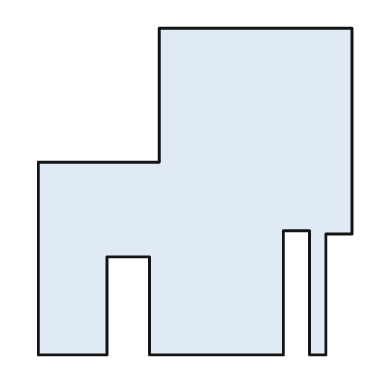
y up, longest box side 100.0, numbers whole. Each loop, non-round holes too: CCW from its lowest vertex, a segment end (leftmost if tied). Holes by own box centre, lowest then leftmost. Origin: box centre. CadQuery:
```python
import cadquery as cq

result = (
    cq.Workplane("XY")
    .moveTo(-48.0, -50.0)
    .lineTo(-27.0, -50.0)
    .lineTo(-27.0, -20.0)
    .lineTo(-14.0, -20.0)
    .lineTo(-14.0, -50.0)
    .lineTo(27.0, -50.0)
    .lineTo(27.0, -12.0)
    .lineTo(35.0, -12.0)
    .lineTo(35.0, -50.0)
    .lineTo(40.0, -50.0)
    .lineTo(40.0, -13.0)
    .lineTo(48.0, -13.0)
    .lineTo(48.0, 50.0)
    .lineTo(-11.0, 50.0)
    .lineTo(-11.0, 9.0)
    .lineTo(-48.0, 9.0)
    .close()
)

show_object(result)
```